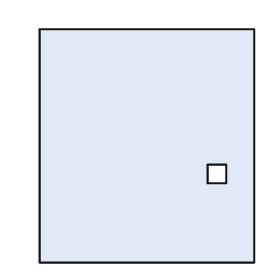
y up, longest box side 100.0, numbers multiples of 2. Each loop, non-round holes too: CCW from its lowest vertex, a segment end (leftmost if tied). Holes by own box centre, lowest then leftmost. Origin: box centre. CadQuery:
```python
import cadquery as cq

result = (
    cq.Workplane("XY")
    .moveTo(-46.0, -50.0)
    .lineTo(46.0, -50.0)
    .lineTo(46.0, 50.0)
    .lineTo(-46.0, 50.0)
    .close()
    .moveTo(26.0, -16.0)
    .lineTo(34.0, -16.0)
    .lineTo(34.0, -8.0)
    .lineTo(26.0, -8.0)
    .close()
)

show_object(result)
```